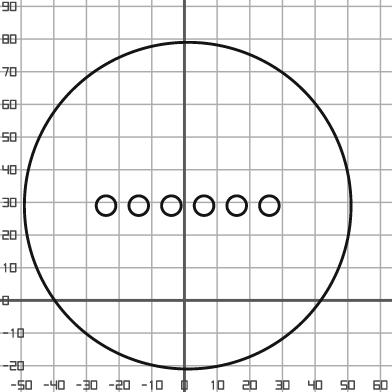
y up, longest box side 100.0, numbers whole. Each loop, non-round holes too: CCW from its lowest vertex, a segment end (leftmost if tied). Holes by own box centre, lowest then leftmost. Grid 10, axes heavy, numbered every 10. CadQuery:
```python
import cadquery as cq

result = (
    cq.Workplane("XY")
    .moveTo(1.0, 29.0)
    .circle(50.0)
    .moveTo(-24.0, 29.0)
    .circle(3.0)
    .moveTo(-14.0, 29.0)
    .circle(3.0)
    .moveTo(-4.0, 29.0)
    .circle(3.0)
    .moveTo(6.0, 29.0)
    .circle(3.0)
    .moveTo(16.0, 29.0)
    .circle(3.0)
    .moveTo(26.0, 29.0)
    .circle(3.0)
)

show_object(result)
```